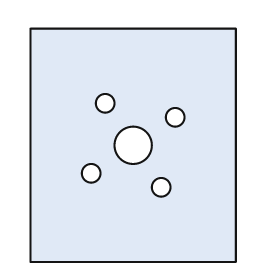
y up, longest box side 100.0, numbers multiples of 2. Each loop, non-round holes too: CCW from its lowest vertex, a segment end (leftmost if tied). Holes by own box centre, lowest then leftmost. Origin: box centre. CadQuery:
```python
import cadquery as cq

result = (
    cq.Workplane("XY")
    .moveTo(-44.0, -50.0)
    .lineTo(44.0, -50.0)
    .lineTo(44.0, 50.0)
    .lineTo(-44.0, 50.0)
    .close()
    .moveTo(12.0, -18.0)
    .circle(4.0)
    .moveTo(-18.0, -12.0)
    .circle(4.0)
    .moveTo(0.0, 0.0)
    .circle(8.0)
    .moveTo(18.0, 12.0)
    .circle(4.0)
    .moveTo(-12.0, 18.0)
    .circle(4.0)
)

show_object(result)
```